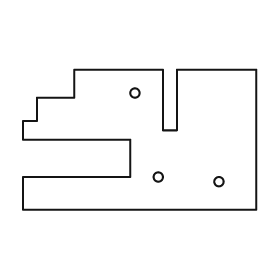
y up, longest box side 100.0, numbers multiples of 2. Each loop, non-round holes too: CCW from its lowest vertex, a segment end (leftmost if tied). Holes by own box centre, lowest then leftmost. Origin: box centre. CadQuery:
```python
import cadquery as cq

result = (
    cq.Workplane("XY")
    .moveTo(-50.0, -30.0)
    .lineTo(50.0, -30.0)
    .lineTo(50.0, 30.0)
    .lineTo(16.0, 30.0)
    .lineTo(16.0, 4.0)
    .lineTo(10.0, 4.0)
    .lineTo(10.0, 30.0)
    .lineTo(-28.0, 30.0)
    .lineTo(-28.0, 18.0)
    .lineTo(-44.0, 18.0)
    .lineTo(-44.0, 8.0)
    .lineTo(-50.0, 8.0)
    .lineTo(-50.0, 0.0)
    .lineTo(-4.0, 0.0)
    .lineTo(-4.0, -16.0)
    .lineTo(-50.0, -16.0)
    .close()
    .moveTo(34.0, -18.0)
    .circle(2.0)
    .moveTo(8.0, -16.0)
    .circle(2.0)
    .moveTo(-2.0, 20.0)
    .circle(2.0)
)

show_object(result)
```